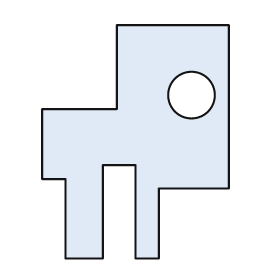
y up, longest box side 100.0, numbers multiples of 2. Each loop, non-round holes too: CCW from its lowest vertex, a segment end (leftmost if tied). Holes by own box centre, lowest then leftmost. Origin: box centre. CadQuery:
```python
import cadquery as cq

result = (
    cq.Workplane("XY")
    .moveTo(-30.0, -50.0)
    .lineTo(-14.0, -50.0)
    .lineTo(-14.0, -10.0)
    .lineTo(0.0, -10.0)
    .lineTo(0.0, -50.0)
    .lineTo(10.0, -50.0)
    .lineTo(10.0, -20.0)
    .lineTo(40.0, -20.0)
    .lineTo(40.0, 50.0)
    .lineTo(-8.0, 50.0)
    .lineTo(-8.0, 14.0)
    .lineTo(-40.0, 14.0)
    .lineTo(-40.0, -16.0)
    .lineTo(-30.0, -16.0)
    .close()
    .moveTo(24.0, 20.0)
    .circle(10.0)
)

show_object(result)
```